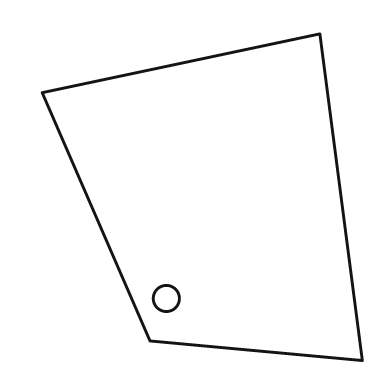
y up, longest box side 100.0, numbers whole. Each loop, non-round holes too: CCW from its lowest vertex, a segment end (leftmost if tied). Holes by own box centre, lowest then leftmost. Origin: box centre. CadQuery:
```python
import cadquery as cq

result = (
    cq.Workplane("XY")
    .moveTo(49.0, -50.0)
    .lineTo(36.0, 50.0)
    .lineTo(-49.0, 32.0)
    .lineTo(-16.0, -44.0)
    .close()
    .moveTo(-11.0, -31.0)
    .circle(4.0)
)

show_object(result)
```